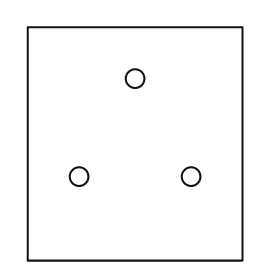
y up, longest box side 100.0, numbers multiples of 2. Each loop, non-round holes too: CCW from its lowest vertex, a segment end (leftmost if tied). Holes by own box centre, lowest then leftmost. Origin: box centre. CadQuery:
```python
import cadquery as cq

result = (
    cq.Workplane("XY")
    .moveTo(-46.0, -50.0)
    .lineTo(46.0, -50.0)
    .lineTo(46.0, 50.0)
    .lineTo(-46.0, 50.0)
    .close()
    .moveTo(-24.0, -14.0)
    .circle(4.0)
    .moveTo(24.0, -14.0)
    .circle(4.0)
    .moveTo(0.0, 28.0)
    .circle(4.0)
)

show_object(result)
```